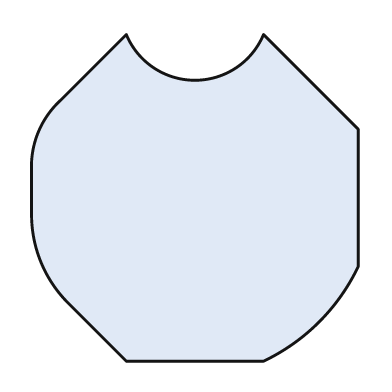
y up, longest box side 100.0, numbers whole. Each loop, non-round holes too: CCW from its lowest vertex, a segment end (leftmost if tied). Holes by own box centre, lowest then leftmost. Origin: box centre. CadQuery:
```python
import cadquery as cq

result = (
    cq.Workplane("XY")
    .moveTo(-21.0, -50.0)
    .lineTo(21.0, -50.0)
    .threePointArc((38.0, -38.0), (50.0, -21.0))
    .lineTo(50.0, 21.0)
    .lineTo(21.0, 50.0)
    .threePointArc((0.0, 36.0), (-21.0, 50.0))
    .lineTo(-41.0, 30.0)
    .threePointArc((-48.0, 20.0), (-50.0, 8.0))
    .lineTo(-50.0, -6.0)
    .threePointArc((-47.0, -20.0), (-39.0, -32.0))
    .close()
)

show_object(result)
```